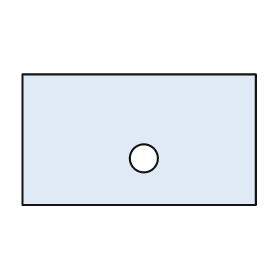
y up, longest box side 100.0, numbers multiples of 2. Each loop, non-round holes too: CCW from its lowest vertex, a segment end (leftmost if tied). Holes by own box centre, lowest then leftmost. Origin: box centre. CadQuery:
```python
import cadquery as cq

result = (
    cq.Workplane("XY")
    .moveTo(-50.0, -28.0)
    .lineTo(50.0, -28.0)
    .lineTo(50.0, 28.0)
    .lineTo(-50.0, 28.0)
    .close()
    .moveTo(2.0, -8.0)
    .circle(6.0)
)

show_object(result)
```